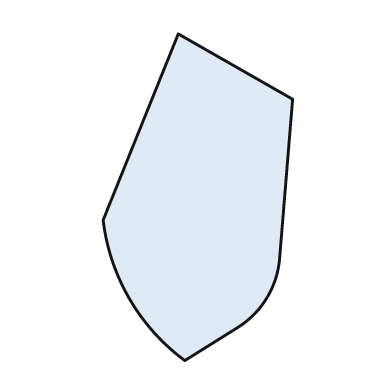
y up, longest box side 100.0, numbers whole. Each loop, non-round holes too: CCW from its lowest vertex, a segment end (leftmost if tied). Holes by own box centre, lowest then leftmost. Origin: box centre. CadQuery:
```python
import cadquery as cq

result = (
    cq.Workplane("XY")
    .moveTo(-4.0, -50.0)
    .lineTo(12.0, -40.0)
    .threePointArc((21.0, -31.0), (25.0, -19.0))
    .lineTo(29.0, 30.0)
    .lineTo(-6.0, 50.0)
    .lineTo(-29.0, -7.0)
    .threePointArc((-21.0, -31.0), (-4.0, -50.0))
    .close()
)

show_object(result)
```